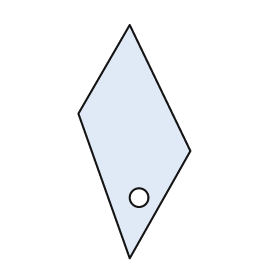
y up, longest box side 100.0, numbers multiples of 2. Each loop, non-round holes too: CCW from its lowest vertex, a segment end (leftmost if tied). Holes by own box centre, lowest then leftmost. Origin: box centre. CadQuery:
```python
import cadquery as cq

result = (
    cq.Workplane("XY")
    .moveTo(-2.0, -50.0)
    .lineTo(24.0, -4.0)
    .lineTo(-2.0, 50.0)
    .lineTo(-24.0, 12.0)
    .close()
    .moveTo(2.0, -24.0)
    .circle(4.0)
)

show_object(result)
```